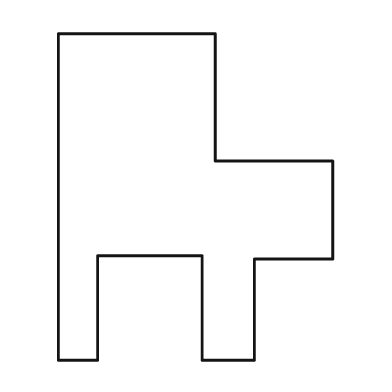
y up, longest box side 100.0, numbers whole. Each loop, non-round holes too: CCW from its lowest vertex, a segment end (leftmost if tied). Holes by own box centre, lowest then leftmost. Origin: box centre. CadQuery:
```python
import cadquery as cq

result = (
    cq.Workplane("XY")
    .moveTo(-42.0, -50.0)
    .lineTo(-30.0, -50.0)
    .lineTo(-30.0, -18.0)
    .lineTo(2.0, -18.0)
    .lineTo(2.0, -50.0)
    .lineTo(18.0, -50.0)
    .lineTo(18.0, -19.0)
    .lineTo(42.0, -19.0)
    .lineTo(42.0, 11.0)
    .lineTo(6.0, 11.0)
    .lineTo(6.0, 50.0)
    .lineTo(-42.0, 50.0)
    .close()
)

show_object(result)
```